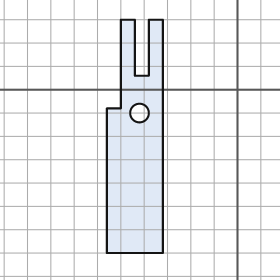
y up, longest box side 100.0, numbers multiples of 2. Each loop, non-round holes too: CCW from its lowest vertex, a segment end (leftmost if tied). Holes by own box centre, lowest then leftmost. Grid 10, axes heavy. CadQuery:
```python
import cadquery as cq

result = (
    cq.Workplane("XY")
    .moveTo(-56.0, -70.0)
    .lineTo(-32.0, -70.0)
    .lineTo(-32.0, 30.0)
    .lineTo(-38.0, 30.0)
    .lineTo(-38.0, 6.0)
    .lineTo(-44.0, 6.0)
    .lineTo(-44.0, 30.0)
    .lineTo(-50.0, 30.0)
    .lineTo(-50.0, -8.0)
    .lineTo(-56.0, -8.0)
    .close()
    .moveTo(-42.0, -10.0)
    .circle(4.0)
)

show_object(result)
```